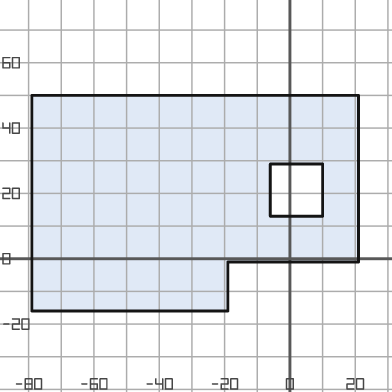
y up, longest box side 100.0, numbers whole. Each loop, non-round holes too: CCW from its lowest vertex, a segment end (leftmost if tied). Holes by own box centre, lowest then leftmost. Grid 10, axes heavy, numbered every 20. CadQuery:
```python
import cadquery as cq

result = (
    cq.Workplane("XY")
    .moveTo(-79.0, -16.0)
    .lineTo(-19.0, -16.0)
    .lineTo(-19.0, -1.0)
    .lineTo(21.0, -1.0)
    .lineTo(21.0, 50.0)
    .lineTo(-79.0, 50.0)
    .close()
    .moveTo(-6.0, 13.0)
    .lineTo(10.0, 13.0)
    .lineTo(10.0, 29.0)
    .lineTo(-6.0, 29.0)
    .close()
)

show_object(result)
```